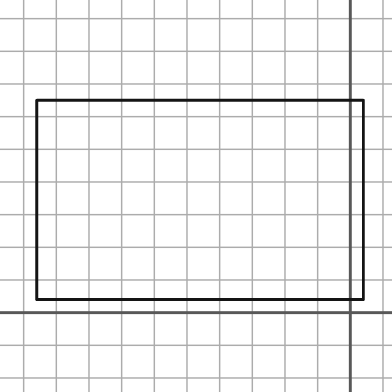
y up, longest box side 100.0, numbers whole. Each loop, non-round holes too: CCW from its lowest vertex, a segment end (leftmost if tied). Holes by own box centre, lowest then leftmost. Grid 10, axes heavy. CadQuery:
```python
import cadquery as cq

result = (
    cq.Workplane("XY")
    .moveTo(-96.0, 4.0)
    .lineTo(4.0, 4.0)
    .lineTo(4.0, 65.0)
    .lineTo(-96.0, 65.0)
    .close()
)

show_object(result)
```